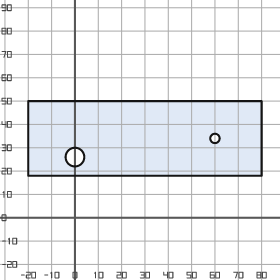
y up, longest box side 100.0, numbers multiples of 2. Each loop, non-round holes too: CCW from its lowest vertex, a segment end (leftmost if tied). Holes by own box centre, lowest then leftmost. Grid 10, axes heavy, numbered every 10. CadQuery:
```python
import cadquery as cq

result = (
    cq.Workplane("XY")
    .moveTo(-20.0, 18.0)
    .lineTo(80.0, 18.0)
    .lineTo(80.0, 50.0)
    .lineTo(-20.0, 50.0)
    .close()
    .moveTo(0.0, 26.0)
    .circle(4.0)
    .moveTo(60.0, 34.0)
    .circle(2.0)
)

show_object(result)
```